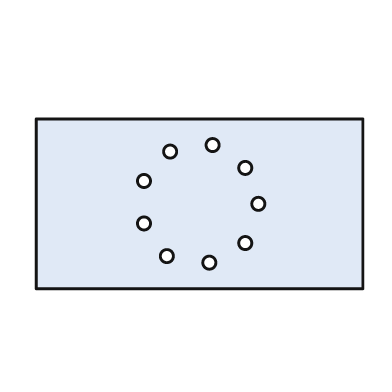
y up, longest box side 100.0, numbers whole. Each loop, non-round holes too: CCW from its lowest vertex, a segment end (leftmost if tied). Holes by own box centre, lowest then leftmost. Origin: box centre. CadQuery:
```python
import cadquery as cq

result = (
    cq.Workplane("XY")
    .moveTo(-50.0, -26.0)
    .lineTo(50.0, -26.0)
    .lineTo(50.0, 26.0)
    .lineTo(-50.0, 26.0)
    .close()
    .moveTo(3.0, -18.0)
    .circle(2.0)
    .moveTo(-10.0, -16.0)
    .circle(2.0)
    .moveTo(14.0, -12.0)
    .circle(2.0)
    .moveTo(-17.0, -6.0)
    .circle(2.0)
    .moveTo(18.0, 0.0)
    .circle(2.0)
    .moveTo(-17.0, 7.0)
    .circle(2.0)
    .moveTo(14.0, 11.0)
    .circle(2.0)
    .moveTo(-9.0, 16.0)
    .circle(2.0)
    .moveTo(4.0, 18.0)
    .circle(2.0)
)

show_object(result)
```